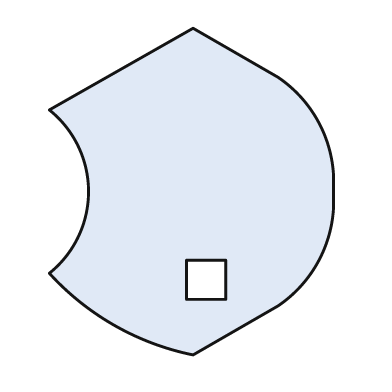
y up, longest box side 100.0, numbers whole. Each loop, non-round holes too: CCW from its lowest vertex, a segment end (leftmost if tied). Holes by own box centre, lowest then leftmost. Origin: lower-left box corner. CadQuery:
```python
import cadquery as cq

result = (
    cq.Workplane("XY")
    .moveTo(44.0, 0.0)
    .lineTo(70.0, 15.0)
    .threePointArc((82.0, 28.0), (87.0, 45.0))
    .lineTo(87.0, 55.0)
    .threePointArc((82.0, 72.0), (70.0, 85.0))
    .lineTo(44.0, 100.0)
    .lineTo(0.0, 75.0)
    .threePointArc((12.0, 50.0), (0.0, 25.0))
    .threePointArc((20.0, 9.0), (44.0, 0.0))
    .close()
    .moveTo(42.0, 17.0)
    .lineTo(54.0, 17.0)
    .lineTo(54.0, 29.0)
    .lineTo(42.0, 29.0)
    .close()
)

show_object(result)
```